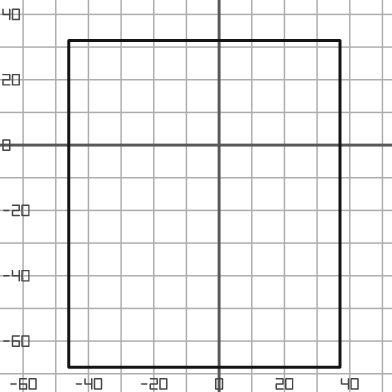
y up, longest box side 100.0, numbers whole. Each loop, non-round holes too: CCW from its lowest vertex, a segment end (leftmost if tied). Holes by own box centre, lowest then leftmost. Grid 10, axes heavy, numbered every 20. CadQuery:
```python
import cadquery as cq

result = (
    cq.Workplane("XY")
    .moveTo(-46.0, -68.0)
    .lineTo(37.0, -68.0)
    .lineTo(37.0, 32.0)
    .lineTo(-46.0, 32.0)
    .close()
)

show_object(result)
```